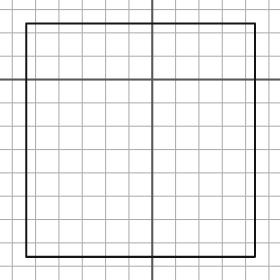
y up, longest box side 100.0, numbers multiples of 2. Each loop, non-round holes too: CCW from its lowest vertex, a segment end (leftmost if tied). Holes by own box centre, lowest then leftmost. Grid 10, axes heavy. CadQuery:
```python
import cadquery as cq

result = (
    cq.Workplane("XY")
    .moveTo(-54.0, -76.0)
    .lineTo(44.0, -76.0)
    .lineTo(44.0, 24.0)
    .lineTo(-54.0, 24.0)
    .close()
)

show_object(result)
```